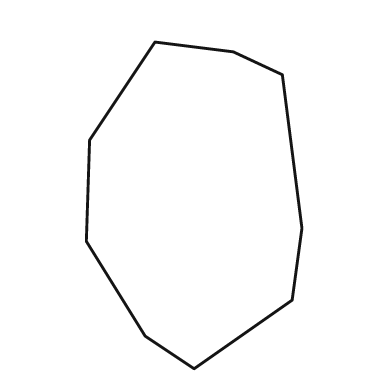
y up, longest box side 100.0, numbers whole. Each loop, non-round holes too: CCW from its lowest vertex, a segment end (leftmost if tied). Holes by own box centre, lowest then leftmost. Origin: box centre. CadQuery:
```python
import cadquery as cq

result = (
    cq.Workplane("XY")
    .moveTo(0.0, -50.0)
    .lineTo(30.0, -29.0)
    .lineTo(33.0, -7.0)
    .lineTo(27.0, 40.0)
    .lineTo(12.0, 47.0)
    .lineTo(-12.0, 50.0)
    .lineTo(-32.0, 20.0)
    .lineTo(-33.0, -11.0)
    .lineTo(-15.0, -40.0)
    .close()
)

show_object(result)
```